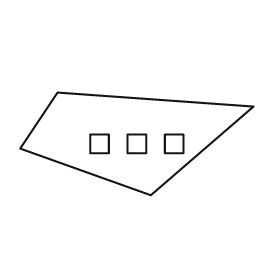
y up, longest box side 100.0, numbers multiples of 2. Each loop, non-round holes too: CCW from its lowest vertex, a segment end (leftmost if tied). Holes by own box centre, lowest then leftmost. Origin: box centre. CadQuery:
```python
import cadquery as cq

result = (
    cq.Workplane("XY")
    .moveTo(6.0, -22.0)
    .lineTo(50.0, 16.0)
    .lineTo(-34.0, 22.0)
    .lineTo(-50.0, -2.0)
    .close()
    .moveTo(-20.0, -4.0)
    .lineTo(-12.0, -4.0)
    .lineTo(-12.0, 4.0)
    .lineTo(-20.0, 4.0)
    .close()
    .moveTo(-4.0, -4.0)
    .lineTo(4.0, -4.0)
    .lineTo(4.0, 4.0)
    .lineTo(-4.0, 4.0)
    .close()
    .moveTo(12.0, -4.0)
    .lineTo(20.0, -4.0)
    .lineTo(20.0, 4.0)
    .lineTo(12.0, 4.0)
    .close()
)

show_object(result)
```